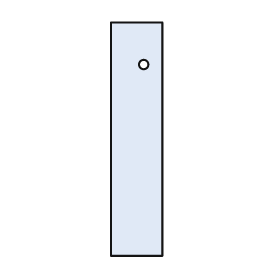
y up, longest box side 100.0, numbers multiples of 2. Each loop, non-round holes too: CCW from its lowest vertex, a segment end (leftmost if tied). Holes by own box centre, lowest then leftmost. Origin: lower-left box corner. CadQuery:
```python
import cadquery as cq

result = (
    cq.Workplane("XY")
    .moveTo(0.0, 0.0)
    .lineTo(22.0, 0.0)
    .lineTo(22.0, 100.0)
    .lineTo(0.0, 100.0)
    .close()
    .moveTo(14.0, 82.0)
    .circle(2.0)
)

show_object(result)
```